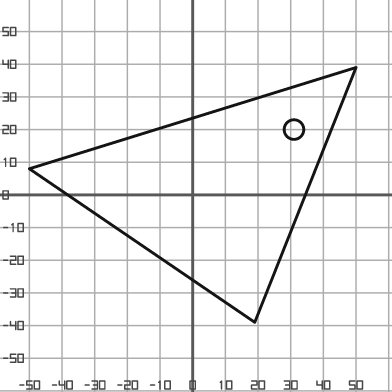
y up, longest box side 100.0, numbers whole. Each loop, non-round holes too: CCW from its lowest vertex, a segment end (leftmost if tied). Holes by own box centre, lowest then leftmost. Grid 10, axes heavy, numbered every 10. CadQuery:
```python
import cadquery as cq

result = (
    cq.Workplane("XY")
    .moveTo(19.0, -39.0)
    .lineTo(50.0, 39.0)
    .lineTo(-50.0, 8.0)
    .close()
    .moveTo(31.0, 20.0)
    .circle(3.0)
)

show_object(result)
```